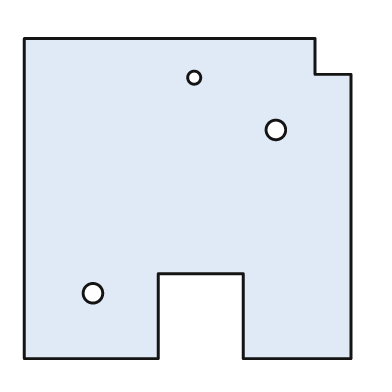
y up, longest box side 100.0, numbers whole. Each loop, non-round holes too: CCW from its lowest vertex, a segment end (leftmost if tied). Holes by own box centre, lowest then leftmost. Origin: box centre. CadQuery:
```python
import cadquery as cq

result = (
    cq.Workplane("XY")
    .moveTo(-50.0, -49.0)
    .lineTo(-9.0, -49.0)
    .lineTo(-9.0, -23.0)
    .lineTo(17.0, -23.0)
    .lineTo(17.0, -49.0)
    .lineTo(50.0, -49.0)
    .lineTo(50.0, 38.0)
    .lineTo(39.0, 38.0)
    .lineTo(39.0, 49.0)
    .lineTo(-50.0, 49.0)
    .close()
    .moveTo(-29.0, -29.0)
    .circle(3.0)
    .moveTo(27.0, 21.0)
    .circle(3.0)
    .moveTo(2.0, 37.0)
    .circle(2.0)
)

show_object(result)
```